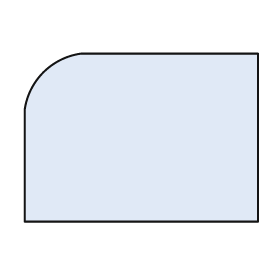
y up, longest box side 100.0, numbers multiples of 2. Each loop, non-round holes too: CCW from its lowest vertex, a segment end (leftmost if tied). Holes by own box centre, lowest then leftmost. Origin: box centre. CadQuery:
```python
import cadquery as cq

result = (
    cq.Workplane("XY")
    .moveTo(-50.0, -36.0)
    .lineTo(50.0, -36.0)
    .lineTo(50.0, 36.0)
    .lineTo(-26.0, 36.0)
    .threePointArc((-42.0, 28.0), (-50.0, 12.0))
    .close()
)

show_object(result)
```